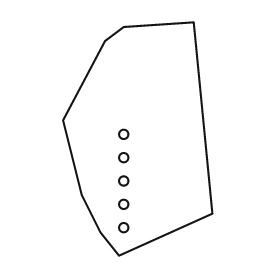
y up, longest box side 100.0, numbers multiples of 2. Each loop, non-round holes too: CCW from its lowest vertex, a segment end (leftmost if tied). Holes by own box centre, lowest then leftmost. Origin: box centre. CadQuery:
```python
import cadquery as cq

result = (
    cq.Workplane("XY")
    .moveTo(-8.0, -50.0)
    .lineTo(32.0, -32.0)
    .lineTo(24.0, 50.0)
    .lineTo(-6.0, 48.0)
    .lineTo(-14.0, 42.0)
    .lineTo(-32.0, 8.0)
    .lineTo(-24.0, -24.0)
    .lineTo(-16.0, -40.0)
    .close()
    .moveTo(-6.0, -38.0)
    .circle(2.0)
    .moveTo(-6.0, -28.0)
    .circle(2.0)
    .moveTo(-6.0, -18.0)
    .circle(2.0)
    .moveTo(-6.0, -8.0)
    .circle(2.0)
    .moveTo(-6.0, 2.0)
    .circle(2.0)
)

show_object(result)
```